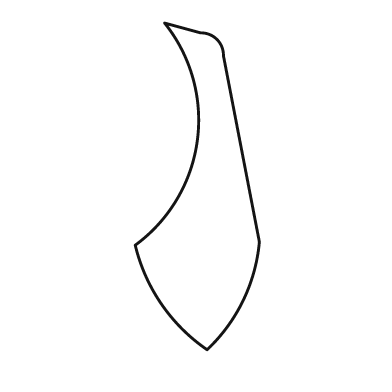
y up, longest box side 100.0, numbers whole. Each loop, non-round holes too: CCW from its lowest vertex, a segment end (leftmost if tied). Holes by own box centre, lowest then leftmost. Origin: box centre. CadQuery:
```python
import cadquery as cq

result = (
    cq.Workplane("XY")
    .moveTo(3.0, -50.0)
    .threePointArc((14.0, -35.0), (19.0, -17.0))
    .lineTo(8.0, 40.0)
    .threePointArc((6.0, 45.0), (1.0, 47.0))
    .lineTo(-10.0, 50.0)
    .threePointArc((0.0, 14.0), (-19.0, -18.0))
    .threePointArc((-11.0, -36.0), (3.0, -50.0))
    .close()
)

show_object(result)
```